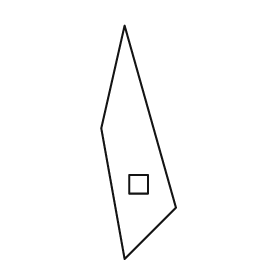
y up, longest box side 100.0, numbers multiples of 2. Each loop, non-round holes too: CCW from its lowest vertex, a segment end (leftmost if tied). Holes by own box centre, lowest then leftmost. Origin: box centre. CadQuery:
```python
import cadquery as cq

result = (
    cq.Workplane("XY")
    .moveTo(-6.0, -50.0)
    .lineTo(16.0, -28.0)
    .lineTo(-6.0, 50.0)
    .lineTo(-16.0, 6.0)
    .close()
    .moveTo(-4.0, -22.0)
    .lineTo(4.0, -22.0)
    .lineTo(4.0, -14.0)
    .lineTo(-4.0, -14.0)
    .close()
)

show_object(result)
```